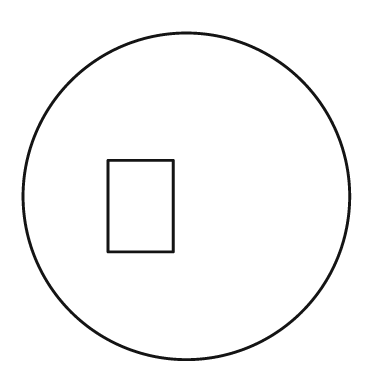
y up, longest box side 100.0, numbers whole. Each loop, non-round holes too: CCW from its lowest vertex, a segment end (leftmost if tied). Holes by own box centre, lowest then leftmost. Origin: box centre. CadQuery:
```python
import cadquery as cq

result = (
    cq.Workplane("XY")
    .moveTo(0.0, 0.0)
    .circle(50.0)
    .moveTo(-24.0, -17.0)
    .lineTo(-4.0, -17.0)
    .lineTo(-4.0, 11.0)
    .lineTo(-24.0, 11.0)
    .close()
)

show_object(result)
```